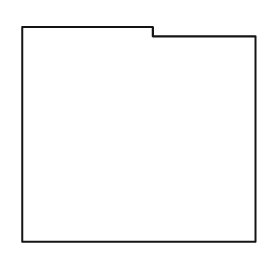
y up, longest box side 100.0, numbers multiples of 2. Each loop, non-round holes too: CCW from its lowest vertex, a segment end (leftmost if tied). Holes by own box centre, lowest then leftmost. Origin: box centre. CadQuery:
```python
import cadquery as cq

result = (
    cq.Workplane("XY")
    .moveTo(-50.0, -46.0)
    .lineTo(50.0, -46.0)
    .lineTo(50.0, 42.0)
    .lineTo(6.0, 42.0)
    .lineTo(6.0, 46.0)
    .lineTo(-50.0, 46.0)
    .close()
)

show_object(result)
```